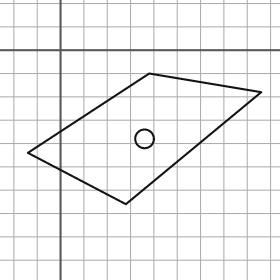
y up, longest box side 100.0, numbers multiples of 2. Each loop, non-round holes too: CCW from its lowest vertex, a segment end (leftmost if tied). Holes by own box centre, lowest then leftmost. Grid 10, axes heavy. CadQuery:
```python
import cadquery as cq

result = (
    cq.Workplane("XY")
    .moveTo(28.0, -66.0)
    .lineTo(86.0, -18.0)
    .lineTo(38.0, -10.0)
    .lineTo(-14.0, -44.0)
    .close()
    .moveTo(36.0, -38.0)
    .circle(4.0)
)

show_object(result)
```